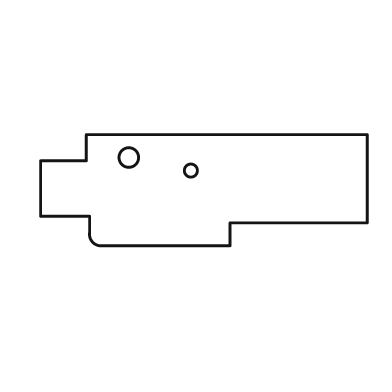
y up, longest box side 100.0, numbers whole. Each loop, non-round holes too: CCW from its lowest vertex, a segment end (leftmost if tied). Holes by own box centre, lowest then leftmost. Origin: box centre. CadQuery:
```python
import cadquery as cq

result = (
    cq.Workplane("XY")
    .moveTo(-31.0, -17.0)
    .lineTo(8.0, -17.0)
    .lineTo(8.0, -10.0)
    .lineTo(50.0, -10.0)
    .lineTo(50.0, 17.0)
    .lineTo(-36.0, 17.0)
    .lineTo(-36.0, 9.0)
    .lineTo(-50.0, 9.0)
    .lineTo(-50.0, -8.0)
    .lineTo(-35.0, -8.0)
    .lineTo(-35.0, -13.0)
    .threePointArc((-34.0, -16.0), (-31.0, -17.0))
    .close()
    .moveTo(-4.0, 6.0)
    .circle(2.0)
    .moveTo(-23.0, 10.0)
    .circle(3.0)
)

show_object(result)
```